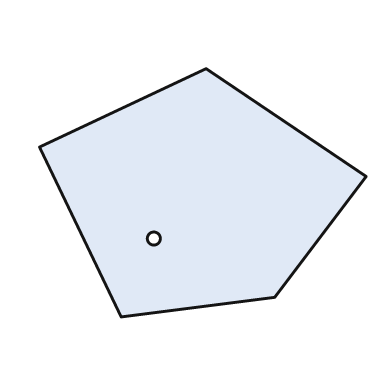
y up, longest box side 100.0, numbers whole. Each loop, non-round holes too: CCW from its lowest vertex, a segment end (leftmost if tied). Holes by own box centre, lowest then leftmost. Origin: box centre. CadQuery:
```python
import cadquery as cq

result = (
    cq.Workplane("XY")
    .moveTo(-25.0, -38.0)
    .lineTo(22.0, -32.0)
    .lineTo(50.0, 5.0)
    .lineTo(1.0, 38.0)
    .lineTo(-50.0, 14.0)
    .close()
    .moveTo(-15.0, -14.0)
    .circle(2.0)
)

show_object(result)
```